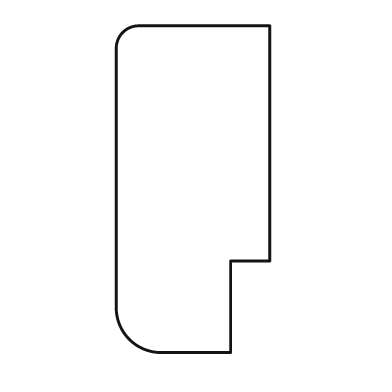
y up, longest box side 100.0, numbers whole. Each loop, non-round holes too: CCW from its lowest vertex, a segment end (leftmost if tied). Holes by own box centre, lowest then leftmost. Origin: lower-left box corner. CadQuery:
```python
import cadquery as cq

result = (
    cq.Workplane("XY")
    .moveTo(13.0, 0.0)
    .lineTo(35.0, 0.0)
    .lineTo(35.0, 28.0)
    .lineTo(47.0, 28.0)
    .lineTo(47.0, 100.0)
    .lineTo(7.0, 100.0)
    .threePointArc((2.0, 98.0), (0.0, 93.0))
    .lineTo(0.0, 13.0)
    .threePointArc((4.0, 4.0), (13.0, 0.0))
    .close()
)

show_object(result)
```